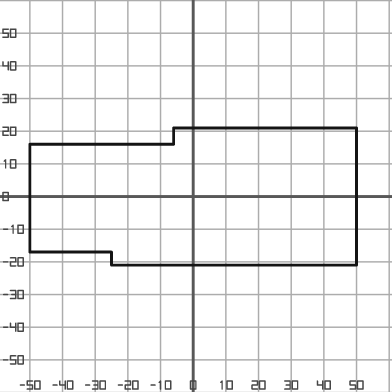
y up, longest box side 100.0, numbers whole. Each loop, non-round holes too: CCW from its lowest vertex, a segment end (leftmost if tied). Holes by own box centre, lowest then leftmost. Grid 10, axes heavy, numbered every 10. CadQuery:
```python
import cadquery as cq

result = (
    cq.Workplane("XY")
    .moveTo(-25.0, -21.0)
    .lineTo(50.0, -21.0)
    .lineTo(50.0, 21.0)
    .lineTo(-6.0, 21.0)
    .lineTo(-6.0, 16.0)
    .lineTo(-50.0, 16.0)
    .lineTo(-50.0, -17.0)
    .lineTo(-25.0, -17.0)
    .close()
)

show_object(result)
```